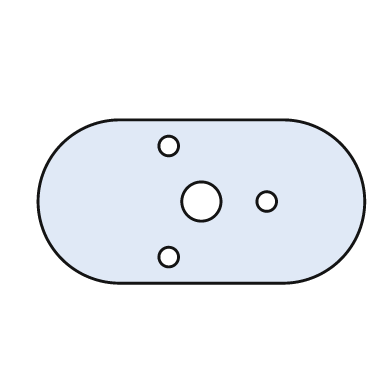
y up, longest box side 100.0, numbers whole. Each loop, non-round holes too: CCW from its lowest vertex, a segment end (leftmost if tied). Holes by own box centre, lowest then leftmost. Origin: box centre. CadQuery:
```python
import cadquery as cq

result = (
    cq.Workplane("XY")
    .moveTo(-25.0, -25.0)
    .lineTo(25.0, -25.0)
    .threePointArc((50.0, 0.0), (25.0, 25.0))
    .lineTo(-25.0, 25.0)
    .threePointArc((-50.0, 0.0), (-25.0, -25.0))
    .close()
    .moveTo(-10.0, -17.0)
    .circle(3.0)
    .moveTo(0.0, 0.0)
    .circle(6.0)
    .moveTo(20.0, 0.0)
    .circle(3.0)
    .moveTo(-10.0, 17.0)
    .circle(3.0)
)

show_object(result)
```